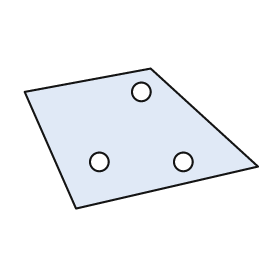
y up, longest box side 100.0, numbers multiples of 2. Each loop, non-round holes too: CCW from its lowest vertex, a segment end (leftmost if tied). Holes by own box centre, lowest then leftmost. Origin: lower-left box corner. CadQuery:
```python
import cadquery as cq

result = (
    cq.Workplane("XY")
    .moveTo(22.0, 0.0)
    .lineTo(100.0, 18.0)
    .lineTo(54.0, 60.0)
    .lineTo(0.0, 50.0)
    .close()
    .moveTo(32.0, 20.0)
    .circle(4.0)
    .moveTo(68.0, 20.0)
    .circle(4.0)
    .moveTo(50.0, 50.0)
    .circle(4.0)
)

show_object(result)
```